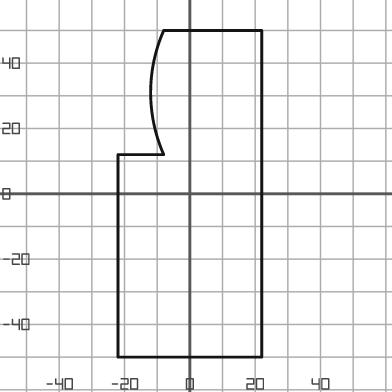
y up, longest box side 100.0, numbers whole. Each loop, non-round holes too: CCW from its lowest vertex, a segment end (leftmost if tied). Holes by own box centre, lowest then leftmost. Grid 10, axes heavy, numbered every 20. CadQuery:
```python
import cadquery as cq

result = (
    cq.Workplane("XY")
    .moveTo(-22.0, -50.0)
    .lineTo(22.0, -50.0)
    .lineTo(22.0, 50.0)
    .lineTo(-8.0, 50.0)
    .threePointArc((-12.0, 31.0), (-8.0, 12.0))
    .lineTo(-22.0, 12.0)
    .close()
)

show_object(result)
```